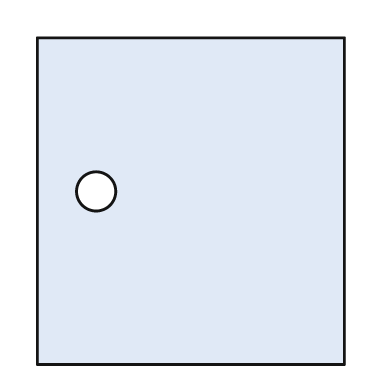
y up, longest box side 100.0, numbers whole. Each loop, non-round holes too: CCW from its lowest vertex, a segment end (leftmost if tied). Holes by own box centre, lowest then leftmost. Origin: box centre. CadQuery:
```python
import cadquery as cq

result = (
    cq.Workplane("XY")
    .moveTo(-47.0, -50.0)
    .lineTo(47.0, -50.0)
    .lineTo(47.0, 50.0)
    .lineTo(-47.0, 50.0)
    .close()
    .moveTo(-29.0, 3.0)
    .circle(6.0)
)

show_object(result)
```